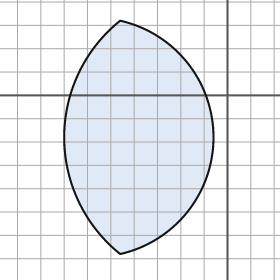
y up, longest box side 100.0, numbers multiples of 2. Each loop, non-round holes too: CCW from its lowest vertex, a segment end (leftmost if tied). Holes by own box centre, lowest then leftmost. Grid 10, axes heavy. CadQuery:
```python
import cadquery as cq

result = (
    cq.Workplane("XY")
    .moveTo(-46.0, -68.0)
    .threePointArc((-6.0, -18.0), (-46.0, 32.0))
    .threePointArc((-70.0, -18.0), (-46.0, -68.0))
    .close()
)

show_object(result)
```